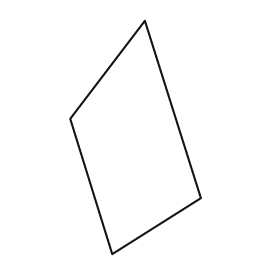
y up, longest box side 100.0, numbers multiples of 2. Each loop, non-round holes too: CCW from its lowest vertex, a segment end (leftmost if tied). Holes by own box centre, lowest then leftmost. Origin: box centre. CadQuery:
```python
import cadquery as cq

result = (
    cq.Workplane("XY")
    .moveTo(-10.0, -50.0)
    .lineTo(28.0, -26.0)
    .lineTo(4.0, 50.0)
    .lineTo(-28.0, 8.0)
    .close()
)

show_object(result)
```